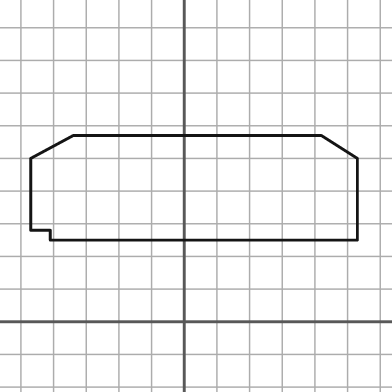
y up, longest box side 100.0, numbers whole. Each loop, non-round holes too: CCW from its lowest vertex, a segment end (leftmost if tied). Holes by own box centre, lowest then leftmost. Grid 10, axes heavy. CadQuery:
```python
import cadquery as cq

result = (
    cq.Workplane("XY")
    .moveTo(-41.0, 25.0)
    .lineTo(53.0, 25.0)
    .lineTo(53.0, 50.0)
    .lineTo(42.0, 57.0)
    .lineTo(-34.0, 57.0)
    .lineTo(-47.0, 50.0)
    .lineTo(-47.0, 28.0)
    .lineTo(-41.0, 28.0)
    .close()
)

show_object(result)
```